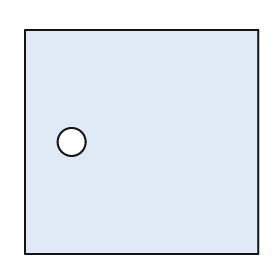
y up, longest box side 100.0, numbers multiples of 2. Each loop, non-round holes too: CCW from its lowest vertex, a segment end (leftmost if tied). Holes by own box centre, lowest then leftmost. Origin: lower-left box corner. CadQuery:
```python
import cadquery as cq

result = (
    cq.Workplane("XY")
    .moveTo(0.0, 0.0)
    .lineTo(100.0, 0.0)
    .lineTo(100.0, 96.0)
    .lineTo(0.0, 96.0)
    .close()
    .moveTo(20.0, 48.0)
    .circle(6.0)
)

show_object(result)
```